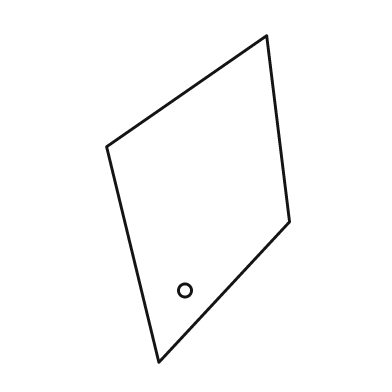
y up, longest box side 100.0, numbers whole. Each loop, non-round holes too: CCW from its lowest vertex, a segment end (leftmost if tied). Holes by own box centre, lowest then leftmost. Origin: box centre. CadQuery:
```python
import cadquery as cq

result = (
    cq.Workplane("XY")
    .moveTo(-12.0, -50.0)
    .lineTo(28.0, -7.0)
    .lineTo(21.0, 50.0)
    .lineTo(-28.0, 16.0)
    .close()
    .moveTo(-4.0, -28.0)
    .circle(2.0)
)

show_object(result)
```